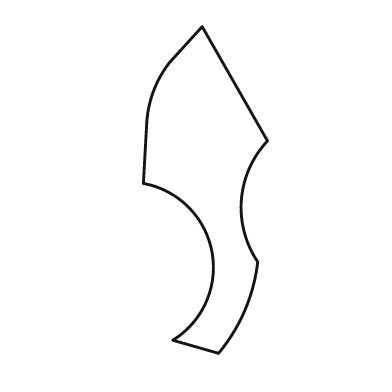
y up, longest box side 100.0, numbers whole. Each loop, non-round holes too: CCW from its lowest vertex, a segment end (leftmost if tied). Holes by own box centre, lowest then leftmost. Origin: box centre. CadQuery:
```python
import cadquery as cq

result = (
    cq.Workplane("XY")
    .moveTo(4.0, -50.0)
    .threePointArc((12.0, -37.0), (16.0, -22.0))
    .threePointArc((11.0, -3.0), (19.0, 15.0))
    .lineTo(-1.0, 50.0)
    .lineTo(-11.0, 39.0)
    .threePointArc((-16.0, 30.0), (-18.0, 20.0))
    .lineTo(-19.0, 2.0)
    .threePointArc((2.0, -19.0), (-10.0, -46.0))
    .close()
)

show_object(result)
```